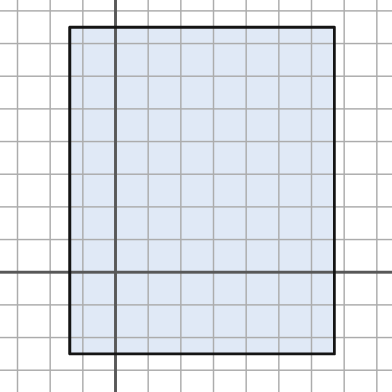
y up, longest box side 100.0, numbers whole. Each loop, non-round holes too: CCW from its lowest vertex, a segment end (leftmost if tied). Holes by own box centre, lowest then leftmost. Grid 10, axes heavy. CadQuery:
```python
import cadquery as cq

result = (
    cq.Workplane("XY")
    .moveTo(-14.0, -25.0)
    .lineTo(67.0, -25.0)
    .lineTo(67.0, 75.0)
    .lineTo(-14.0, 75.0)
    .close()
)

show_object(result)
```